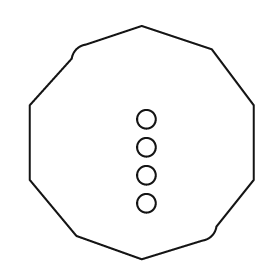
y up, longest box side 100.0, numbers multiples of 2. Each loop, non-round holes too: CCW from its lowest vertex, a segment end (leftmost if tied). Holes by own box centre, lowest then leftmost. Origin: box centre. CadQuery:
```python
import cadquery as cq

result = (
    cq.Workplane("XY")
    .moveTo(0.0, -50.0)
    .lineTo(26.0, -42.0)
    .threePointArc((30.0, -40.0), (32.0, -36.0))
    .lineTo(48.0, -16.0)
    .lineTo(48.0, 16.0)
    .lineTo(30.0, 40.0)
    .lineTo(0.0, 50.0)
    .lineTo(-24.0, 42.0)
    .threePointArc((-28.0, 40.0), (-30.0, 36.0))
    .lineTo(-48.0, 16.0)
    .lineTo(-48.0, -16.0)
    .lineTo(-28.0, -40.0)
    .close()
    .moveTo(2.0, -26.0)
    .circle(4.0)
    .moveTo(2.0, -14.0)
    .circle(4.0)
    .moveTo(2.0, -2.0)
    .circle(4.0)
    .moveTo(2.0, 10.0)
    .circle(4.0)
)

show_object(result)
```